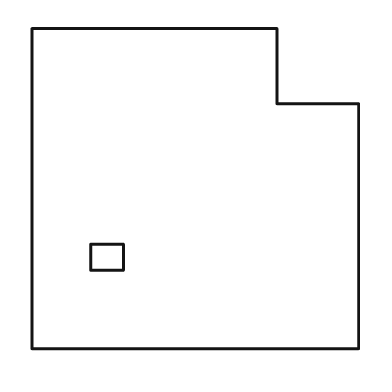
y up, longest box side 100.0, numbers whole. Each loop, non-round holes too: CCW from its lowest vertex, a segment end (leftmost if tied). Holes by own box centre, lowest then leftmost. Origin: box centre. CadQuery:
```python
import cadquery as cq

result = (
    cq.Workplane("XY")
    .moveTo(-50.0, -49.0)
    .lineTo(50.0, -49.0)
    .lineTo(50.0, 26.0)
    .lineTo(25.0, 26.0)
    .lineTo(25.0, 49.0)
    .lineTo(-50.0, 49.0)
    .close()
    .moveTo(-32.0, -25.0)
    .lineTo(-22.0, -25.0)
    .lineTo(-22.0, -17.0)
    .lineTo(-32.0, -17.0)
    .close()
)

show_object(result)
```